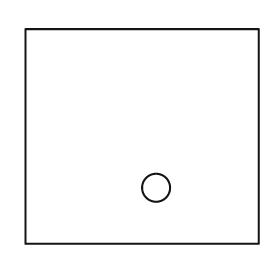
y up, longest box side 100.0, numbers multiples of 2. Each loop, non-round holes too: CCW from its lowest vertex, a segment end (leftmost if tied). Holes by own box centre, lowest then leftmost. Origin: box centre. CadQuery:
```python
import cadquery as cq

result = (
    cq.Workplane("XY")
    .moveTo(-50.0, -46.0)
    .lineTo(50.0, -46.0)
    .lineTo(50.0, 46.0)
    .lineTo(-50.0, 46.0)
    .close()
    .moveTo(6.0, -22.0)
    .circle(6.0)
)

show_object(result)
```